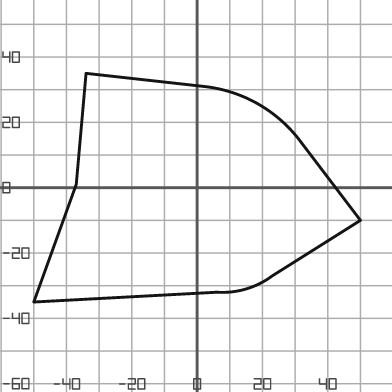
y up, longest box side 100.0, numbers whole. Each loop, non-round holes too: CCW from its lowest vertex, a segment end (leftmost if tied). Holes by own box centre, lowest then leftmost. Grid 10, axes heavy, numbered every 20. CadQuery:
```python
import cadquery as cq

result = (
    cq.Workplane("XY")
    .moveTo(-50.0, -35.0)
    .lineTo(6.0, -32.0)
    .threePointArc((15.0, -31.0), (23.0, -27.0))
    .lineTo(50.0, -10.0)
    .lineTo(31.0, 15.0)
    .threePointArc((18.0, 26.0), (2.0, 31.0))
    .lineTo(-34.0, 35.0)
    .lineTo(-37.0, 1.0)
    .close()
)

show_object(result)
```